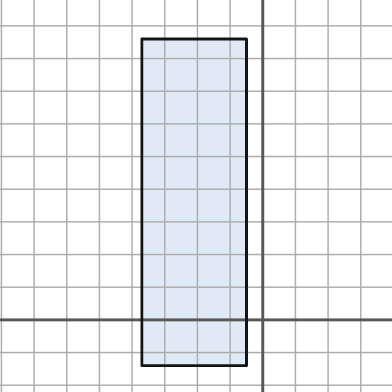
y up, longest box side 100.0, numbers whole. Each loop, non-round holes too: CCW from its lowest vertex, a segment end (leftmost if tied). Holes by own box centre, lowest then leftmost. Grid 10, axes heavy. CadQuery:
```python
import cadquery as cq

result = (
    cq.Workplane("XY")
    .moveTo(-37.0, -14.0)
    .lineTo(-5.0, -14.0)
    .lineTo(-5.0, 86.0)
    .lineTo(-37.0, 86.0)
    .close()
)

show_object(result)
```